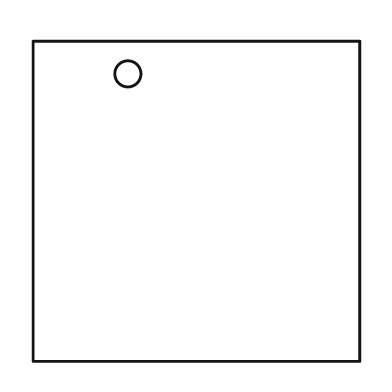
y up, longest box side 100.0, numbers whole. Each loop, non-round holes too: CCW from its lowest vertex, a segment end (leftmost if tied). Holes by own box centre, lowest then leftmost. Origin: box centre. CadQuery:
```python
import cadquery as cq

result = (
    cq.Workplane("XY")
    .moveTo(-50.0, -49.0)
    .lineTo(50.0, -49.0)
    .lineTo(50.0, 49.0)
    .lineTo(-50.0, 49.0)
    .close()
    .moveTo(-21.0, 39.0)
    .circle(4.0)
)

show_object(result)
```